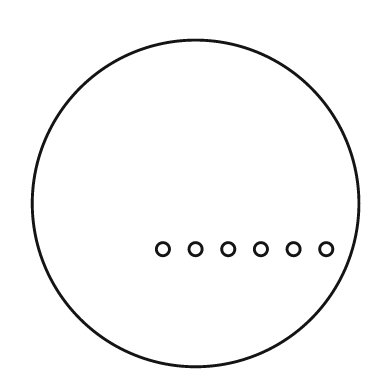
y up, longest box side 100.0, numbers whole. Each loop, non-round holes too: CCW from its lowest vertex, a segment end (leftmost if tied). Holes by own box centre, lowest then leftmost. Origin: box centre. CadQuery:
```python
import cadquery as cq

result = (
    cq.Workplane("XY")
    .moveTo(0.0, 0.0)
    .circle(50.0)
    .moveTo(-10.0, -14.0)
    .circle(2.0)
    .moveTo(0.0, -14.0)
    .circle(2.0)
    .moveTo(10.0, -14.0)
    .circle(2.0)
    .moveTo(20.0, -14.0)
    .circle(2.0)
    .moveTo(30.0, -14.0)
    .circle(2.0)
    .moveTo(40.0, -14.0)
    .circle(2.0)
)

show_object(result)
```